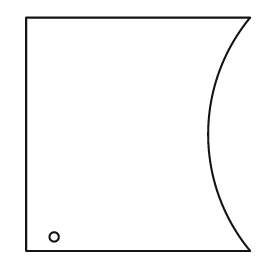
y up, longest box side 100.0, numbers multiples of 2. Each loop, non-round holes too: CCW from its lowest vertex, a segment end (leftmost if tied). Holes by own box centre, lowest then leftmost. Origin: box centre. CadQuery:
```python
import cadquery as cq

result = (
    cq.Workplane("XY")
    .moveTo(-48.0, -50.0)
    .lineTo(48.0, -50.0)
    .threePointArc((30.0, 0.0), (48.0, 50.0))
    .lineTo(-48.0, 50.0)
    .close()
    .moveTo(-36.0, -44.0)
    .circle(2.0)
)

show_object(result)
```